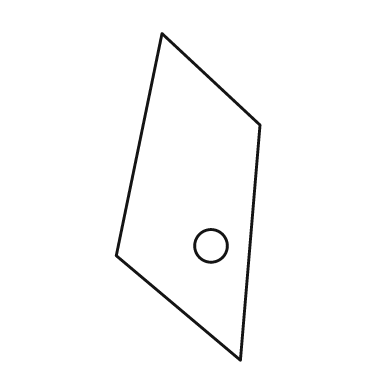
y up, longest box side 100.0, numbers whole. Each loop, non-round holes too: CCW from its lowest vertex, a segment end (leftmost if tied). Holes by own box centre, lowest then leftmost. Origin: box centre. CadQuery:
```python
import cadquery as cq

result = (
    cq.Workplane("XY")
    .moveTo(16.0, -50.0)
    .lineTo(22.0, 22.0)
    .lineTo(-8.0, 50.0)
    .lineTo(-22.0, -18.0)
    .close()
    .moveTo(7.0, -15.0)
    .circle(5.0)
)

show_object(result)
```